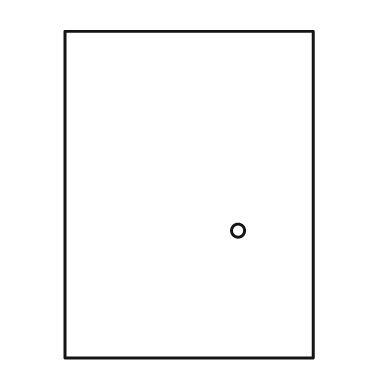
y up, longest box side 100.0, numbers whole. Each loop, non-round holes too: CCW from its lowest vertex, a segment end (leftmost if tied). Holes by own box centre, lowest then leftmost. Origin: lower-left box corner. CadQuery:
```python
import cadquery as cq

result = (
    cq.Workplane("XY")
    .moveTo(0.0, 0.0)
    .lineTo(76.0, 0.0)
    .lineTo(76.0, 100.0)
    .lineTo(0.0, 100.0)
    .close()
    .moveTo(53.0, 39.0)
    .circle(2.0)
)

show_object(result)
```